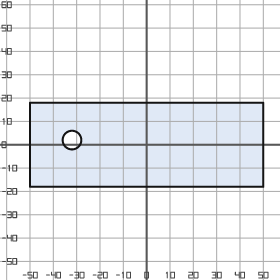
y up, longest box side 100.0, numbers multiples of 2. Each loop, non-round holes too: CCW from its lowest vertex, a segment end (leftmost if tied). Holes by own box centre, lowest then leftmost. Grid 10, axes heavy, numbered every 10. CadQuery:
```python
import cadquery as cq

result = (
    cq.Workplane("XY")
    .moveTo(-50.0, -18.0)
    .lineTo(50.0, -18.0)
    .lineTo(50.0, 18.0)
    .lineTo(-50.0, 18.0)
    .close()
    .moveTo(-32.0, 2.0)
    .circle(4.0)
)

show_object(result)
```